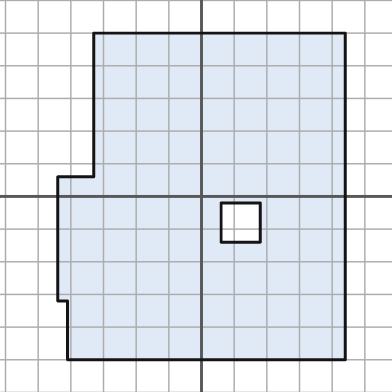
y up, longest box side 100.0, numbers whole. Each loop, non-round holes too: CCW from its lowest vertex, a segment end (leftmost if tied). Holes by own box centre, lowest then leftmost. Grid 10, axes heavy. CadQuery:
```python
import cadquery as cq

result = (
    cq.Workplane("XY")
    .moveTo(-41.0, -50.0)
    .lineTo(44.0, -50.0)
    .lineTo(44.0, 50.0)
    .lineTo(-33.0, 50.0)
    .lineTo(-33.0, 6.0)
    .lineTo(-44.0, 6.0)
    .lineTo(-44.0, -32.0)
    .lineTo(-41.0, -32.0)
    .close()
    .moveTo(6.0, -14.0)
    .lineTo(18.0, -14.0)
    .lineTo(18.0, -2.0)
    .lineTo(6.0, -2.0)
    .close()
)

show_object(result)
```